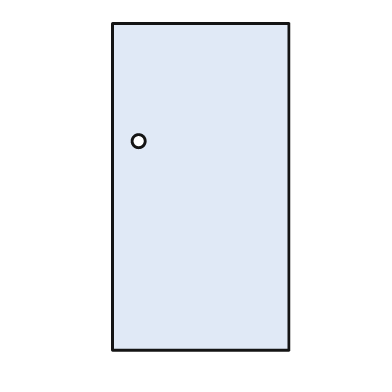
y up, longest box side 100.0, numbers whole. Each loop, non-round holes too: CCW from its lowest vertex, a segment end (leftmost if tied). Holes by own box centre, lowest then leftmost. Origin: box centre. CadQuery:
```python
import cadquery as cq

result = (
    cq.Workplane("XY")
    .moveTo(-27.0, -50.0)
    .lineTo(27.0, -50.0)
    .lineTo(27.0, 50.0)
    .lineTo(-27.0, 50.0)
    .close()
    .moveTo(-19.0, 14.0)
    .circle(2.0)
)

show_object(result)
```